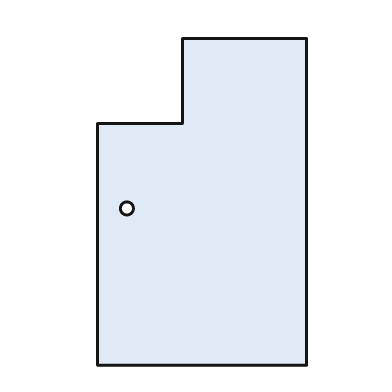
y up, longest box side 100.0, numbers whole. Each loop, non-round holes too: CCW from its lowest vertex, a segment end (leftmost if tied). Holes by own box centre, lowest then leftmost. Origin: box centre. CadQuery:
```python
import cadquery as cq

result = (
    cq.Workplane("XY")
    .moveTo(-32.0, -50.0)
    .lineTo(32.0, -50.0)
    .lineTo(32.0, 50.0)
    .lineTo(-6.0, 50.0)
    .lineTo(-6.0, 24.0)
    .lineTo(-32.0, 24.0)
    .close()
    .moveTo(-23.0, -2.0)
    .circle(2.0)
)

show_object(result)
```